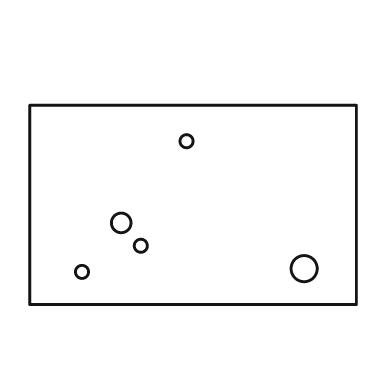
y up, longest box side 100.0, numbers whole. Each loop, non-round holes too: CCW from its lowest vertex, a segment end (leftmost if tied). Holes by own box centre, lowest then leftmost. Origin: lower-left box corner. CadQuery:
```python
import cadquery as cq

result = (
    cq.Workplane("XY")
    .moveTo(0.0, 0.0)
    .lineTo(100.0, 0.0)
    .lineTo(100.0, 61.0)
    .lineTo(0.0, 61.0)
    .close()
    .moveTo(16.0, 10.0)
    .circle(2.0)
    .moveTo(84.0, 11.0)
    .circle(4.0)
    .moveTo(34.0, 18.0)
    .circle(2.0)
    .moveTo(28.0, 25.0)
    .circle(3.0)
    .moveTo(48.0, 50.0)
    .circle(2.0)
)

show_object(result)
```